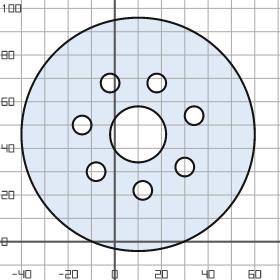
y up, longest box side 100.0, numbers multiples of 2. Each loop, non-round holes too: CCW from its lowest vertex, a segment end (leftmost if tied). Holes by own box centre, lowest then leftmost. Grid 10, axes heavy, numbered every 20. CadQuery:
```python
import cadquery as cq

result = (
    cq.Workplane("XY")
    .moveTo(10.0, 46.0)
    .circle(50.0)
    .moveTo(12.0, 22.0)
    .circle(4.0)
    .moveTo(-8.0, 30.0)
    .circle(4.0)
    .moveTo(30.0, 32.0)
    .circle(4.0)
    .moveTo(10.0, 46.0)
    .circle(12.0)
    .moveTo(-14.0, 50.0)
    .circle(4.0)
    .moveTo(34.0, 54.0)
    .circle(4.0)
    .moveTo(-2.0, 68.0)
    .circle(4.0)
    .moveTo(18.0, 68.0)
    .circle(4.0)
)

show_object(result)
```